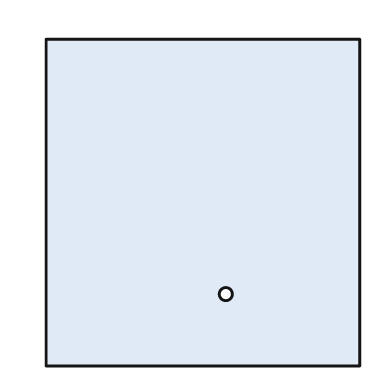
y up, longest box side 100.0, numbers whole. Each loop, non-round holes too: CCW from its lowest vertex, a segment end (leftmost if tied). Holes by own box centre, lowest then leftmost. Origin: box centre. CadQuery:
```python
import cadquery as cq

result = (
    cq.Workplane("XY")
    .moveTo(-48.0, -50.0)
    .lineTo(48.0, -50.0)
    .lineTo(48.0, 50.0)
    .lineTo(-48.0, 50.0)
    .close()
    .moveTo(7.0, -28.0)
    .circle(2.0)
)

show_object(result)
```